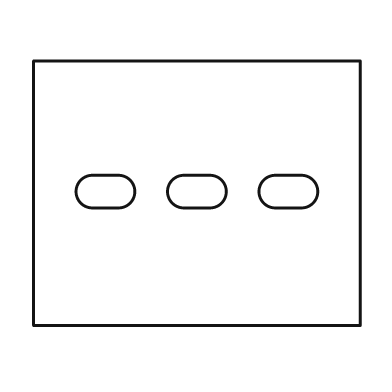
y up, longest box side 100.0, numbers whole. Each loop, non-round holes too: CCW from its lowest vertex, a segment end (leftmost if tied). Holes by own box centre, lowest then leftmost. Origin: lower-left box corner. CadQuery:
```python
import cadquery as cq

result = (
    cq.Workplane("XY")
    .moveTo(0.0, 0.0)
    .lineTo(100.0, 0.0)
    .lineTo(100.0, 81.0)
    .lineTo(0.0, 81.0)
    .close()
    .moveTo(18.0, 36.0)
    .lineTo(26.0, 36.0)
    .threePointArc((31.0, 41.0), (26.0, 46.0))
    .lineTo(18.0, 46.0)
    .threePointArc((13.0, 41.0), (18.0, 36.0))
    .close()
    .moveTo(46.0, 36.0)
    .lineTo(54.0, 36.0)
    .threePointArc((59.0, 41.0), (54.0, 46.0))
    .lineTo(46.0, 46.0)
    .threePointArc((41.0, 41.0), (46.0, 36.0))
    .close()
    .moveTo(74.0, 36.0)
    .lineTo(82.0, 36.0)
    .threePointArc((87.0, 41.0), (82.0, 46.0))
    .lineTo(74.0, 46.0)
    .threePointArc((69.0, 41.0), (74.0, 36.0))
    .close()
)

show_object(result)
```